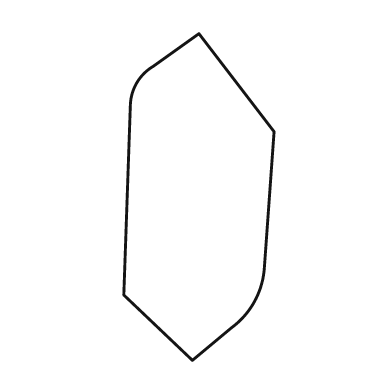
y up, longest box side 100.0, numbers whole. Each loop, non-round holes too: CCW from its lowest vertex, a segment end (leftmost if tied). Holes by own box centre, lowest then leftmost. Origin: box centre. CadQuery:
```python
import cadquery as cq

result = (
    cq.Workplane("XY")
    .moveTo(-2.0, -50.0)
    .lineTo(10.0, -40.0)
    .threePointArc((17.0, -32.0), (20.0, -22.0))
    .lineTo(23.0, 20.0)
    .lineTo(0.0, 50.0)
    .lineTo(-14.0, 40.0)
    .threePointArc((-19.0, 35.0), (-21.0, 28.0))
    .lineTo(-23.0, -30.0)
    .close()
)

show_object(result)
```